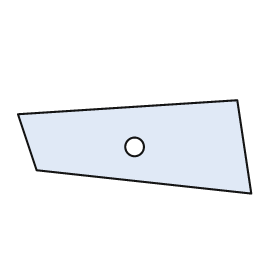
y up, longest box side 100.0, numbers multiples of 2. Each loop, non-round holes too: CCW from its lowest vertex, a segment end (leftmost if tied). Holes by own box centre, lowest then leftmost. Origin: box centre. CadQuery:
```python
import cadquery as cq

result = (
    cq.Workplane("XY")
    .moveTo(50.0, -20.0)
    .lineTo(44.0, 20.0)
    .lineTo(-50.0, 14.0)
    .lineTo(-42.0, -10.0)
    .close()
    .moveTo(0.0, 0.0)
    .circle(4.0)
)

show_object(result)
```